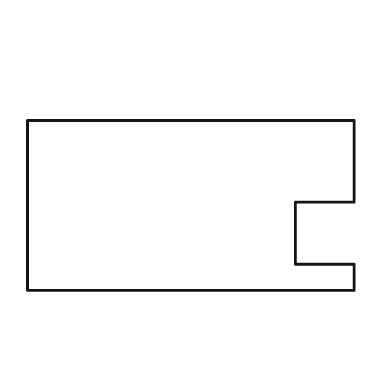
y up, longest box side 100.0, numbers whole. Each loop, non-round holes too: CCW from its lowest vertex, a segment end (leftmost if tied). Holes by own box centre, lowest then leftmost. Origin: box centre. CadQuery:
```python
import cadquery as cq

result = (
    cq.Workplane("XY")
    .moveTo(-50.0, -26.0)
    .lineTo(50.0, -26.0)
    .lineTo(50.0, -18.0)
    .lineTo(32.0, -18.0)
    .lineTo(32.0, 1.0)
    .lineTo(50.0, 1.0)
    .lineTo(50.0, 26.0)
    .lineTo(-50.0, 26.0)
    .close()
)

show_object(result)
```